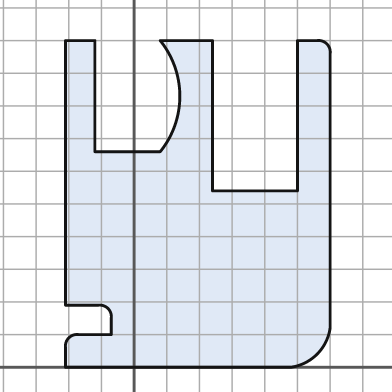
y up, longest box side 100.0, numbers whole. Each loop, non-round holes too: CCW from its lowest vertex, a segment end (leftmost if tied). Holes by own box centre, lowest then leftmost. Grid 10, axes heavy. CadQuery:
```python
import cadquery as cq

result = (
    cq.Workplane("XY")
    .moveTo(-21.0, 0.0)
    .lineTo(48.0, 0.0)
    .threePointArc((56.0, 4.0), (60.0, 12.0))
    .lineTo(60.0, 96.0)
    .threePointArc((59.0, 99.0), (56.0, 100.0))
    .lineTo(50.0, 100.0)
    .lineTo(50.0, 54.0)
    .lineTo(24.0, 54.0)
    .lineTo(24.0, 100.0)
    .lineTo(8.0, 100.0)
    .threePointArc((14.0, 83.0), (8.0, 66.0))
    .lineTo(-12.0, 66.0)
    .lineTo(-12.0, 100.0)
    .lineTo(-21.0, 100.0)
    .lineTo(-21.0, 19.0)
    .lineTo(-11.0, 19.0)
    .threePointArc((-8.0, 18.0), (-7.0, 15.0))
    .lineTo(-7.0, 10.0)
    .lineTo(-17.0, 10.0)
    .threePointArc((-20.0, 9.0), (-21.0, 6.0))
    .close()
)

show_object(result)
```